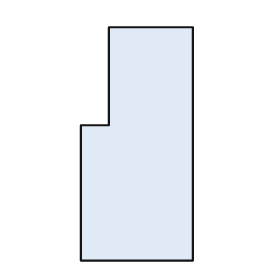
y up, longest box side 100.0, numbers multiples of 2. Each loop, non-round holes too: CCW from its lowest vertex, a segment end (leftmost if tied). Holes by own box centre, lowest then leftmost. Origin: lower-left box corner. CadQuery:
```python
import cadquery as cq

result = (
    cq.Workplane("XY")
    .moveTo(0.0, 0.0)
    .lineTo(48.0, 0.0)
    .lineTo(48.0, 100.0)
    .lineTo(12.0, 100.0)
    .lineTo(12.0, 58.0)
    .lineTo(0.0, 58.0)
    .close()
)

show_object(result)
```